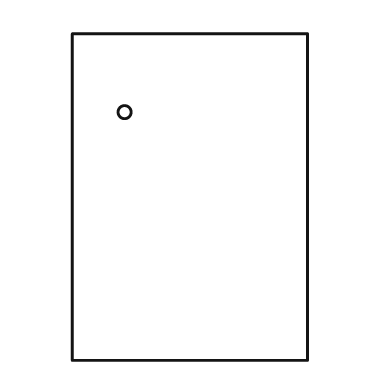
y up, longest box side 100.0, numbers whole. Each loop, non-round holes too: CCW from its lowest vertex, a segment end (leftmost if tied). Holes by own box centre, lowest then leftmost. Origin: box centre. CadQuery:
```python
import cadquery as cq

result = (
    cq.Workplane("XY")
    .moveTo(-36.0, -50.0)
    .lineTo(36.0, -50.0)
    .lineTo(36.0, 50.0)
    .lineTo(-36.0, 50.0)
    .close()
    .moveTo(-20.0, 26.0)
    .circle(2.0)
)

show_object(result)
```